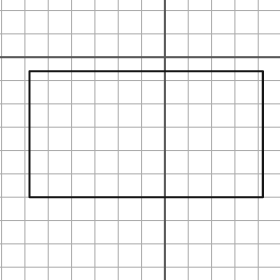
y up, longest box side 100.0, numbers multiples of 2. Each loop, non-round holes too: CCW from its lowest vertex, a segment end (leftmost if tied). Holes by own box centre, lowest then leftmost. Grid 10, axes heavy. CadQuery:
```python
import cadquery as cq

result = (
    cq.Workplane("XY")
    .moveTo(-58.0, -60.0)
    .lineTo(42.0, -60.0)
    .lineTo(42.0, -6.0)
    .lineTo(-58.0, -6.0)
    .close()
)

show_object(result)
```